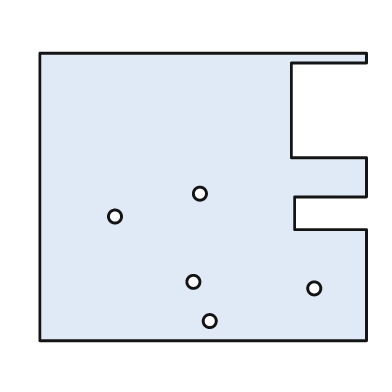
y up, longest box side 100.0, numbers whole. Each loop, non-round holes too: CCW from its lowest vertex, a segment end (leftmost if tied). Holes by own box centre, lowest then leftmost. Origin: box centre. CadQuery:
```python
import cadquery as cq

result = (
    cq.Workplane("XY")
    .moveTo(-50.0, -44.0)
    .lineTo(50.0, -44.0)
    .lineTo(50.0, -10.0)
    .lineTo(28.0, -10.0)
    .lineTo(28.0, 0.0)
    .lineTo(50.0, 0.0)
    .lineTo(50.0, 12.0)
    .lineTo(27.0, 12.0)
    .lineTo(27.0, 41.0)
    .lineTo(50.0, 41.0)
    .lineTo(50.0, 44.0)
    .lineTo(-50.0, 44.0)
    .close()
    .moveTo(2.0, -38.0)
    .circle(2.0)
    .moveTo(34.0, -28.0)
    .circle(2.0)
    .moveTo(-3.0, -26.0)
    .circle(2.0)
    .moveTo(-27.0, -6.0)
    .circle(2.0)
    .moveTo(-1.0, 1.0)
    .circle(2.0)
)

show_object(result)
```